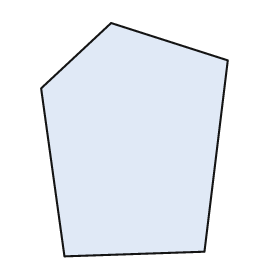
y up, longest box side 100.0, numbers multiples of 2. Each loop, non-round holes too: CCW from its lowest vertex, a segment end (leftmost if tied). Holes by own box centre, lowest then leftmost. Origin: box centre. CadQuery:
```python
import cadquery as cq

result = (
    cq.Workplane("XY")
    .moveTo(-30.0, -50.0)
    .lineTo(30.0, -48.0)
    .lineTo(40.0, 34.0)
    .lineTo(-10.0, 50.0)
    .lineTo(-40.0, 22.0)
    .close()
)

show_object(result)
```